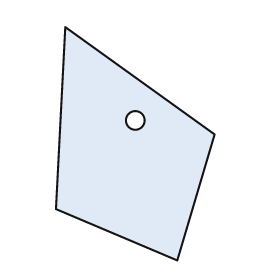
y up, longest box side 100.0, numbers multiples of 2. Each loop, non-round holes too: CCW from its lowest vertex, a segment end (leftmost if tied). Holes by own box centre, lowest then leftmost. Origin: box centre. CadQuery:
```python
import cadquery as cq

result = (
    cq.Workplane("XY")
    .moveTo(18.0, -50.0)
    .lineTo(34.0, 4.0)
    .lineTo(-30.0, 50.0)
    .lineTo(-34.0, -28.0)
    .close()
    .moveTo(0.0, 10.0)
    .circle(4.0)
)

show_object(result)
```